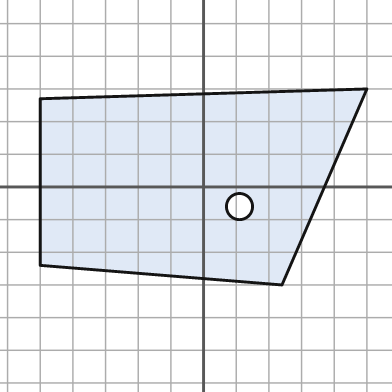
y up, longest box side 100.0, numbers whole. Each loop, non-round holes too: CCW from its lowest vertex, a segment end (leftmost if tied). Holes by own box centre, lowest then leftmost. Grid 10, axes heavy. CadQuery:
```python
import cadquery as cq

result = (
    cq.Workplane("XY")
    .moveTo(24.0, -30.0)
    .lineTo(50.0, 30.0)
    .lineTo(-50.0, 27.0)
    .lineTo(-50.0, -24.0)
    .close()
    .moveTo(11.0, -6.0)
    .circle(4.0)
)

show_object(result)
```